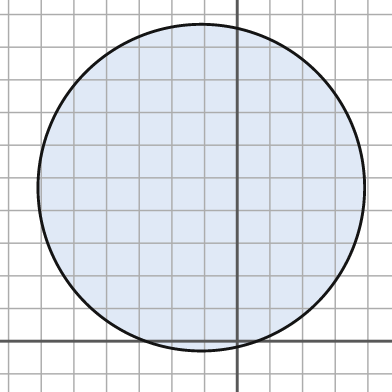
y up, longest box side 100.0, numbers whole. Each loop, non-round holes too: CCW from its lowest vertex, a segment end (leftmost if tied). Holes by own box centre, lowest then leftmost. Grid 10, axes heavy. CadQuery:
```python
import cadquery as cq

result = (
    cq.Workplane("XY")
    .moveTo(-11.0, 47.0)
    .circle(50.0)
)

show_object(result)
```